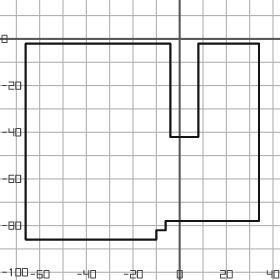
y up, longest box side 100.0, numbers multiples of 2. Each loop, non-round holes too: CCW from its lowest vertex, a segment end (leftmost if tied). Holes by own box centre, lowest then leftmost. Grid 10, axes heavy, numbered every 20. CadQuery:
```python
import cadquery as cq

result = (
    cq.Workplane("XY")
    .moveTo(-66.0, -86.0)
    .lineTo(-10.0, -86.0)
    .lineTo(-10.0, -82.0)
    .lineTo(-6.0, -82.0)
    .lineTo(-6.0, -78.0)
    .lineTo(34.0, -78.0)
    .lineTo(34.0, -2.0)
    .lineTo(8.0, -2.0)
    .lineTo(8.0, -42.0)
    .lineTo(-4.0, -42.0)
    .lineTo(-4.0, -2.0)
    .lineTo(-66.0, -2.0)
    .close()
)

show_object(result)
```